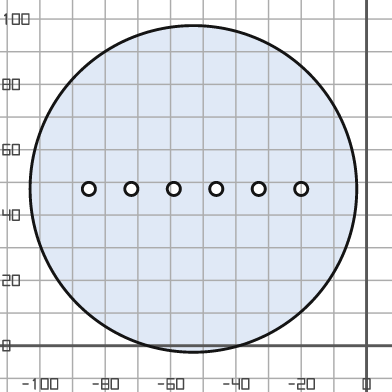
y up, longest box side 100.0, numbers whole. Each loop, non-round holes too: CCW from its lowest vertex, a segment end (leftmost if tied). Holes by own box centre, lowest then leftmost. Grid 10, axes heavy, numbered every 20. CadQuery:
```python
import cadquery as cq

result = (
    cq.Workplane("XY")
    .moveTo(-53.0, 48.0)
    .circle(50.0)
    .moveTo(-85.0, 48.0)
    .circle(2.0)
    .moveTo(-72.0, 48.0)
    .circle(2.0)
    .moveTo(-59.0, 48.0)
    .circle(2.0)
    .moveTo(-46.0, 48.0)
    .circle(2.0)
    .moveTo(-33.0, 48.0)
    .circle(2.0)
    .moveTo(-20.0, 48.0)
    .circle(2.0)
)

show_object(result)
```